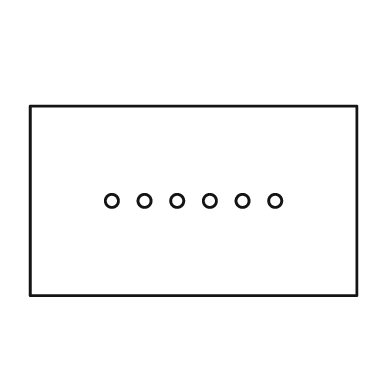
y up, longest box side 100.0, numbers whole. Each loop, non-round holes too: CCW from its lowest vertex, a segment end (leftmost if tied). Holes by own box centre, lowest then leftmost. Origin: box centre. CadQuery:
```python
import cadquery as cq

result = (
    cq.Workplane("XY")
    .moveTo(-50.0, -29.0)
    .lineTo(50.0, -29.0)
    .lineTo(50.0, 29.0)
    .lineTo(-50.0, 29.0)
    .close()
    .moveTo(-25.0, 0.0)
    .circle(2.0)
    .moveTo(-15.0, 0.0)
    .circle(2.0)
    .moveTo(-5.0, 0.0)
    .circle(2.0)
    .moveTo(5.0, 0.0)
    .circle(2.0)
    .moveTo(15.0, 0.0)
    .circle(2.0)
    .moveTo(25.0, 0.0)
    .circle(2.0)
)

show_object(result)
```